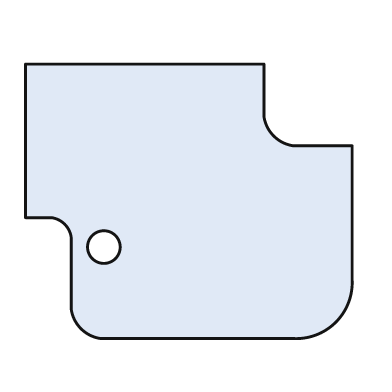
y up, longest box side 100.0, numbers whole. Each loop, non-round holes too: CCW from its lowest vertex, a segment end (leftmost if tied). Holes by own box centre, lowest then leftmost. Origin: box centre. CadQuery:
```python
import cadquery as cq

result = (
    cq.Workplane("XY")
    .moveTo(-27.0, -42.0)
    .lineTo(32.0, -42.0)
    .threePointArc((45.0, -37.0), (50.0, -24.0))
    .lineTo(50.0, 17.0)
    .lineTo(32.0, 17.0)
    .threePointArc((26.0, 20.0), (23.0, 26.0))
    .lineTo(23.0, 42.0)
    .lineTo(-50.0, 42.0)
    .lineTo(-50.0, -5.0)
    .lineTo(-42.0, -5.0)
    .threePointArc((-38.0, -7.0), (-36.0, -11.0))
    .lineTo(-36.0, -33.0)
    .threePointArc((-33.0, -39.0), (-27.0, -42.0))
    .close()
    .moveTo(-26.0, -14.0)
    .circle(5.0)
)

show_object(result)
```